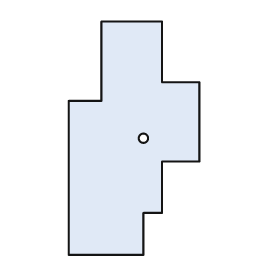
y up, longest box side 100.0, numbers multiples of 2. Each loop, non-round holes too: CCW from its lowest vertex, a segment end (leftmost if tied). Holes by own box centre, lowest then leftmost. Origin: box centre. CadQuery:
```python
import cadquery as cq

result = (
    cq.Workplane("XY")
    .moveTo(-28.0, -50.0)
    .lineTo(4.0, -50.0)
    .lineTo(4.0, -32.0)
    .lineTo(12.0, -32.0)
    .lineTo(12.0, -10.0)
    .lineTo(28.0, -10.0)
    .lineTo(28.0, 24.0)
    .lineTo(12.0, 24.0)
    .lineTo(12.0, 50.0)
    .lineTo(-14.0, 50.0)
    .lineTo(-14.0, 16.0)
    .lineTo(-28.0, 16.0)
    .close()
    .moveTo(4.0, 0.0)
    .circle(2.0)
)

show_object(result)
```